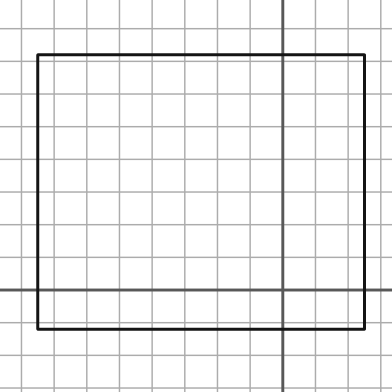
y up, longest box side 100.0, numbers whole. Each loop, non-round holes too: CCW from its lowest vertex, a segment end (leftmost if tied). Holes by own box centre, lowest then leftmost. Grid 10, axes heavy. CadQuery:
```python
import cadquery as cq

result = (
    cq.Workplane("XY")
    .moveTo(-75.0, -12.0)
    .lineTo(25.0, -12.0)
    .lineTo(25.0, 72.0)
    .lineTo(-75.0, 72.0)
    .close()
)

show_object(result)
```